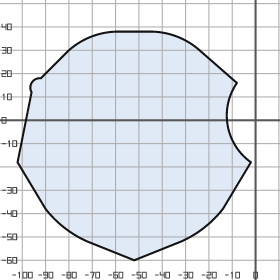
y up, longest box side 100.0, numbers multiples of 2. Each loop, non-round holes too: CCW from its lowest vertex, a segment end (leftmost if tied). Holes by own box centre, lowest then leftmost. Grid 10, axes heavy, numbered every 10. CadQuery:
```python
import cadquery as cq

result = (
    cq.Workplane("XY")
    .moveTo(-52.0, -60.0)
    .lineTo(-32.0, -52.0)
    .threePointArc((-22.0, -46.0), (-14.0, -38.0))
    .lineTo(-2.0, -18.0)
    .threePointArc((-12.0, -2.0), (-8.0, 16.0))
    .lineTo(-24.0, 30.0)
    .threePointArc((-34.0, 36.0), (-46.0, 38.0))
    .lineTo(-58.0, 38.0)
    .threePointArc((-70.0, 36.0), (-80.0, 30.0))
    .lineTo(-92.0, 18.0)
    .threePointArc((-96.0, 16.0), (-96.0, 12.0))
    .lineTo(-102.0, -18.0)
    .lineTo(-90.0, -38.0)
    .threePointArc((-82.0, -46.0), (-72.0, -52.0))
    .close()
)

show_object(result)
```